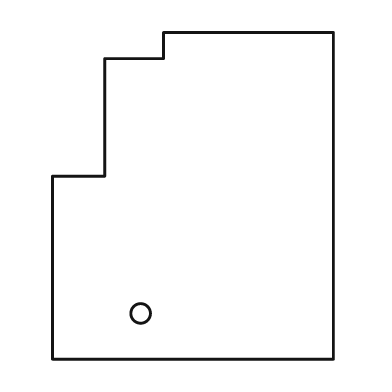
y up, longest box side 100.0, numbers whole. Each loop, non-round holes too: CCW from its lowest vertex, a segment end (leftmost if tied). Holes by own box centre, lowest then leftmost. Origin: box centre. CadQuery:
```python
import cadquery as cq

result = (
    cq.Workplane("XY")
    .moveTo(-43.0, -50.0)
    .lineTo(43.0, -50.0)
    .lineTo(43.0, 50.0)
    .lineTo(-9.0, 50.0)
    .lineTo(-9.0, 42.0)
    .lineTo(-27.0, 42.0)
    .lineTo(-27.0, 6.0)
    .lineTo(-43.0, 6.0)
    .close()
    .moveTo(-16.0, -36.0)
    .circle(3.0)
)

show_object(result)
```